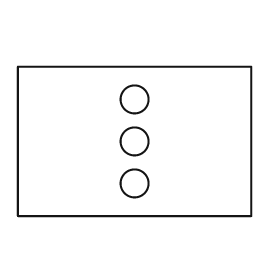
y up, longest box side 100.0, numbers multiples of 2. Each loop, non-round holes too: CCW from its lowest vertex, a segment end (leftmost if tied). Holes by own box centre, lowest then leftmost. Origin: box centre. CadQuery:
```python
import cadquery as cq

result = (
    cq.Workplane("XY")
    .moveTo(-50.0, -32.0)
    .lineTo(50.0, -32.0)
    .lineTo(50.0, 32.0)
    .lineTo(-50.0, 32.0)
    .close()
    .moveTo(0.0, -18.0)
    .circle(6.0)
    .moveTo(0.0, 0.0)
    .circle(6.0)
    .moveTo(0.0, 18.0)
    .circle(6.0)
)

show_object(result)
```